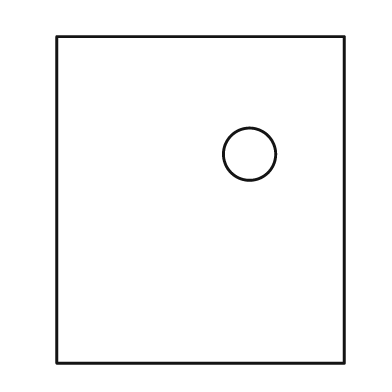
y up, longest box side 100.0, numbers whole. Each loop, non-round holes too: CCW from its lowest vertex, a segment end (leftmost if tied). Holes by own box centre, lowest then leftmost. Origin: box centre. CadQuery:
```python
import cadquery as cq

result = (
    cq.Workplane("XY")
    .moveTo(-44.0, -50.0)
    .lineTo(44.0, -50.0)
    .lineTo(44.0, 50.0)
    .lineTo(-44.0, 50.0)
    .close()
    .moveTo(15.0, 14.0)
    .circle(8.0)
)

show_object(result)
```